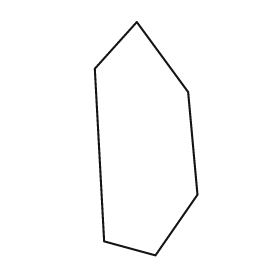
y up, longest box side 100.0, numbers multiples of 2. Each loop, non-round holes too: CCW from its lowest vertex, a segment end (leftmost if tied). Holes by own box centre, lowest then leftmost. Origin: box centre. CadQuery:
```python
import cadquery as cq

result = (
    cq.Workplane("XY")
    .moveTo(4.0, -50.0)
    .lineTo(22.0, -24.0)
    .lineTo(18.0, 20.0)
    .lineTo(-4.0, 50.0)
    .lineTo(-22.0, 30.0)
    .lineTo(-18.0, -44.0)
    .close()
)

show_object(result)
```